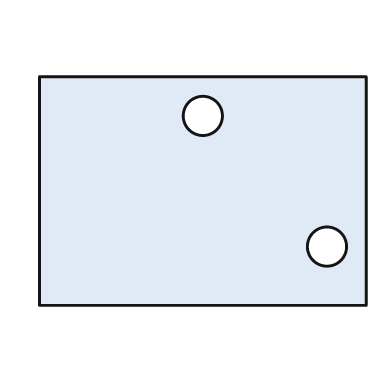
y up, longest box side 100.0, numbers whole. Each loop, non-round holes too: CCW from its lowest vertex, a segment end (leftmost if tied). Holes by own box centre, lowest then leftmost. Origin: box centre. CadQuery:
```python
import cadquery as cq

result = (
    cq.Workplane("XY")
    .moveTo(-50.0, -35.0)
    .lineTo(50.0, -35.0)
    .lineTo(50.0, 35.0)
    .lineTo(-50.0, 35.0)
    .close()
    .moveTo(38.0, -17.0)
    .circle(6.0)
    .moveTo(0.0, 23.0)
    .circle(6.0)
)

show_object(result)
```